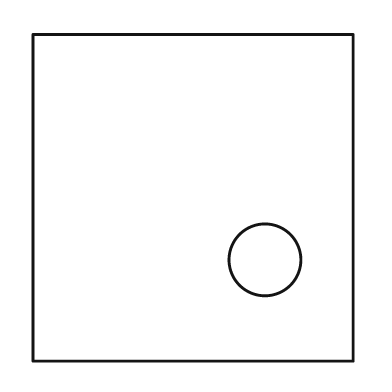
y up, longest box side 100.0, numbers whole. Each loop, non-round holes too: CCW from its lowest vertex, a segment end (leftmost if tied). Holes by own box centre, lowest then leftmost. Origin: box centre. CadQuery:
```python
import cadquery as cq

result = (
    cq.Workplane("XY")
    .moveTo(-49.0, -50.0)
    .lineTo(49.0, -50.0)
    .lineTo(49.0, 50.0)
    .lineTo(-49.0, 50.0)
    .close()
    .moveTo(22.0, -19.0)
    .circle(11.0)
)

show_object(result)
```